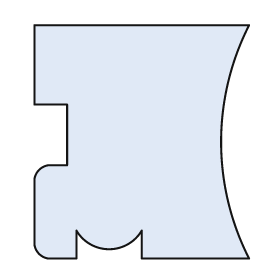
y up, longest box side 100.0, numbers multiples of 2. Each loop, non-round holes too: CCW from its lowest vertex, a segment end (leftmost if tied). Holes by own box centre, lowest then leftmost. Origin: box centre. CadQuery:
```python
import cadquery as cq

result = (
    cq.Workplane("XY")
    .moveTo(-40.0, -50.0)
    .lineTo(-28.0, -50.0)
    .lineTo(-28.0, -38.0)
    .threePointArc((-14.0, -46.0), (0.0, -38.0))
    .lineTo(0.0, -50.0)
    .lineTo(46.0, -50.0)
    .threePointArc((34.0, 0.0), (46.0, 50.0))
    .lineTo(-46.0, 50.0)
    .lineTo(-46.0, 16.0)
    .lineTo(-32.0, 16.0)
    .lineTo(-32.0, -10.0)
    .lineTo(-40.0, -10.0)
    .threePointArc((-44.0, -12.0), (-46.0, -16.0))
    .lineTo(-46.0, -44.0)
    .threePointArc((-44.0, -48.0), (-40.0, -50.0))
    .close()
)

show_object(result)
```